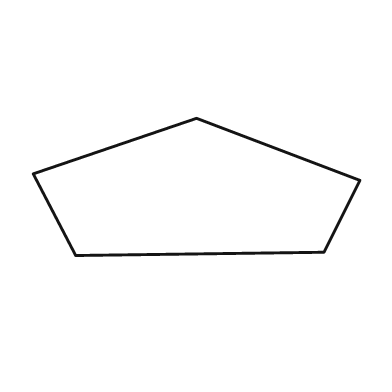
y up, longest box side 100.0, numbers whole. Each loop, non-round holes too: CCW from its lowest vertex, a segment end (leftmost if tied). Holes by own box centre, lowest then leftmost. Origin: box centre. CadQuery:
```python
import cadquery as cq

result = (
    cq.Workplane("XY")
    .moveTo(-37.0, -21.0)
    .lineTo(39.0, -20.0)
    .lineTo(50.0, 2.0)
    .lineTo(0.0, 21.0)
    .lineTo(-50.0, 4.0)
    .close()
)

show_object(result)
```